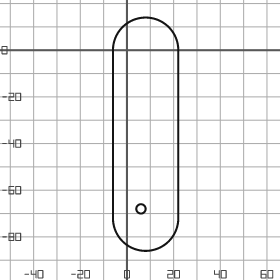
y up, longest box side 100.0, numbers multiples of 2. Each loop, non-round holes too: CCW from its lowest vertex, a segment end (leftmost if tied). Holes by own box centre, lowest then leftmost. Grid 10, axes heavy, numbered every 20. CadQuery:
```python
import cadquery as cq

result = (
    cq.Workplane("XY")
    .moveTo(-6.0, -72.0)
    .threePointArc((8.0, -86.0), (22.0, -72.0))
    .lineTo(22.0, 0.0)
    .threePointArc((8.0, 14.0), (-6.0, 0.0))
    .close()
    .moveTo(6.0, -68.0)
    .circle(2.0)
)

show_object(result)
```